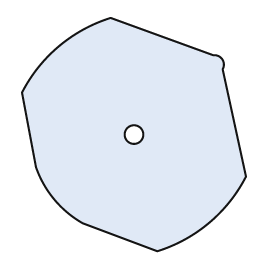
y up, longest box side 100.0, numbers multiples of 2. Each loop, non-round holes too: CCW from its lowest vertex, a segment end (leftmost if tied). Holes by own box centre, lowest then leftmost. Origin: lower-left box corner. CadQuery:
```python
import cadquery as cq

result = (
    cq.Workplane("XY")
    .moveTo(58.0, 0.0)
    .threePointArc((80.0, 12.0), (96.0, 32.0))
    .lineTo(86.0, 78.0)
    .threePointArc((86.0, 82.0), (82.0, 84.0))
    .lineTo(38.0, 100.0)
    .threePointArc((16.0, 88.0), (0.0, 68.0))
    .lineTo(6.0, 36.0)
    .threePointArc((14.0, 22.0), (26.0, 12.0))
    .close()
    .moveTo(48.0, 50.0)
    .circle(4.0)
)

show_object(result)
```